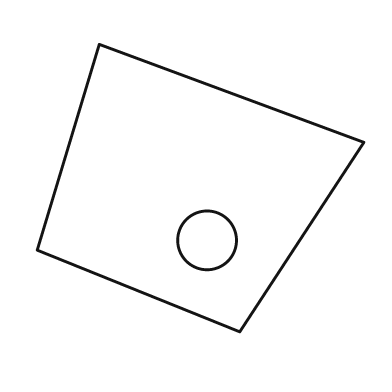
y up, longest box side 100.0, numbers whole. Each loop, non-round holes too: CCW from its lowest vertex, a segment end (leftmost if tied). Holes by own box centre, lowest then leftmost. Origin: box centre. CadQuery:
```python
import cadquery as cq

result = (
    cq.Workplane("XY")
    .moveTo(12.0, -44.0)
    .lineTo(50.0, 14.0)
    .lineTo(-31.0, 44.0)
    .lineTo(-50.0, -19.0)
    .close()
    .moveTo(2.0, -16.0)
    .circle(9.0)
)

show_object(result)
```